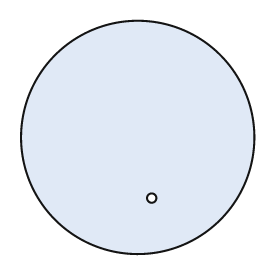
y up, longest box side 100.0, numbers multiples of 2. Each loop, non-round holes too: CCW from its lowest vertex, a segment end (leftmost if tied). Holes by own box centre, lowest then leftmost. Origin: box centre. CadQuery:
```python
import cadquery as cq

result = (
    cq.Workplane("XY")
    .moveTo(0.0, 0.0)
    .circle(50.0)
    .moveTo(6.0, -26.0)
    .circle(2.0)
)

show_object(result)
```